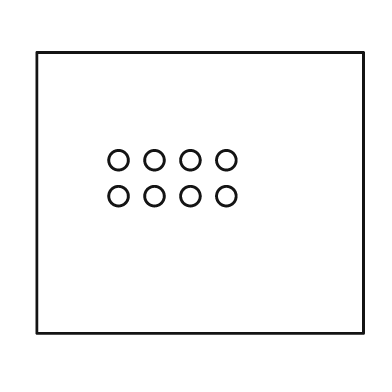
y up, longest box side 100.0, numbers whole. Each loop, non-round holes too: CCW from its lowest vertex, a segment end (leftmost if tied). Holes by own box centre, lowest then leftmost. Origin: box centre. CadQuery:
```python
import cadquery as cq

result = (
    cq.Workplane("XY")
    .moveTo(-50.0, -43.0)
    .lineTo(50.0, -43.0)
    .lineTo(50.0, 43.0)
    .lineTo(-50.0, 43.0)
    .close()
    .moveTo(-25.0, -1.0)
    .circle(3.0)
    .moveTo(-14.0, -1.0)
    .circle(3.0)
    .moveTo(-3.0, -1.0)
    .circle(3.0)
    .moveTo(8.0, -1.0)
    .circle(3.0)
    .moveTo(-25.0, 10.0)
    .circle(3.0)
    .moveTo(-14.0, 10.0)
    .circle(3.0)
    .moveTo(-3.0, 10.0)
    .circle(3.0)
    .moveTo(8.0, 10.0)
    .circle(3.0)
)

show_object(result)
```